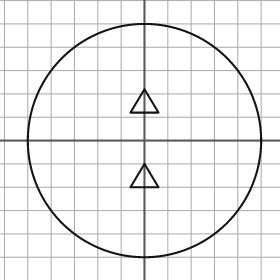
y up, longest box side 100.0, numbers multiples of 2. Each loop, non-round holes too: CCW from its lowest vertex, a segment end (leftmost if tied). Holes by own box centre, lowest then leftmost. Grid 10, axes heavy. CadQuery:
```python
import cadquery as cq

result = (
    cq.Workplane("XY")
    .moveTo(0.0, 0.0)
    .circle(50.0)
    .moveTo(-6.0, -20.0)
    .lineTo(6.0, -20.0)
    .lineTo(0.0, -10.0)
    .close()
    .moveTo(-6.0, 12.0)
    .lineTo(6.0, 12.0)
    .lineTo(0.0, 22.0)
    .close()
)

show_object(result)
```